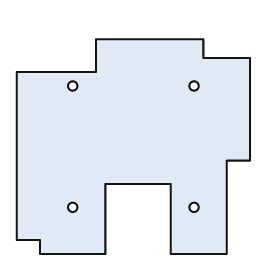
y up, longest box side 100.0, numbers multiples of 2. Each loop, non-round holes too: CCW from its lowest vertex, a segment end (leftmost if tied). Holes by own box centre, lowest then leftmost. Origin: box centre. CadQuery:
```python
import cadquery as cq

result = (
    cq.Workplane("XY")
    .moveTo(-40.0, -46.0)
    .lineTo(-12.0, -46.0)
    .lineTo(-12.0, -16.0)
    .lineTo(16.0, -16.0)
    .lineTo(16.0, -46.0)
    .lineTo(40.0, -46.0)
    .lineTo(40.0, -6.0)
    .lineTo(50.0, -6.0)
    .lineTo(50.0, 38.0)
    .lineTo(30.0, 38.0)
    .lineTo(30.0, 46.0)
    .lineTo(-16.0, 46.0)
    .lineTo(-16.0, 32.0)
    .lineTo(-50.0, 32.0)
    .lineTo(-50.0, -40.0)
    .lineTo(-40.0, -40.0)
    .close()
    .moveTo(-26.0, -26.0)
    .circle(2.0)
    .moveTo(26.0, -26.0)
    .circle(2.0)
    .moveTo(-26.0, 26.0)
    .circle(2.0)
    .moveTo(26.0, 26.0)
    .circle(2.0)
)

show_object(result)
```